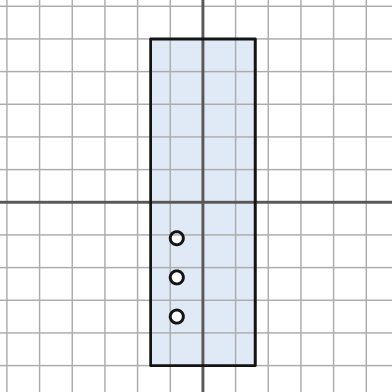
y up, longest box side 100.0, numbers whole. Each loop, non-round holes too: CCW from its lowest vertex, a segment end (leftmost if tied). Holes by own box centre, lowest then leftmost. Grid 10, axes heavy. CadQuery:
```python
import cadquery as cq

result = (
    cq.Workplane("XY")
    .moveTo(-16.0, -50.0)
    .lineTo(16.0, -50.0)
    .lineTo(16.0, 50.0)
    .lineTo(-16.0, 50.0)
    .close()
    .moveTo(-8.0, -35.0)
    .circle(2.0)
    .moveTo(-8.0, -23.0)
    .circle(2.0)
    .moveTo(-8.0, -11.0)
    .circle(2.0)
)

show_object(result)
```